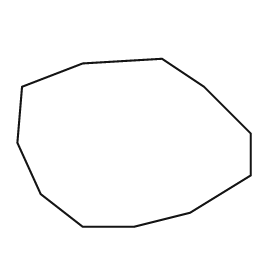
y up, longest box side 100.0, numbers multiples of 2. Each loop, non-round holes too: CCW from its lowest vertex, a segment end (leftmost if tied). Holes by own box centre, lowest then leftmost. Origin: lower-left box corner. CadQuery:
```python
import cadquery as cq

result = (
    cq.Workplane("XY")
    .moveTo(28.0, 0.0)
    .lineTo(50.0, 0.0)
    .lineTo(74.0, 6.0)
    .lineTo(100.0, 22.0)
    .lineTo(100.0, 40.0)
    .lineTo(80.0, 60.0)
    .lineTo(62.0, 72.0)
    .lineTo(28.0, 70.0)
    .lineTo(2.0, 60.0)
    .lineTo(0.0, 36.0)
    .lineTo(10.0, 14.0)
    .close()
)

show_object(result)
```